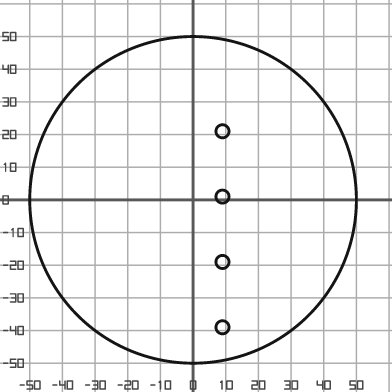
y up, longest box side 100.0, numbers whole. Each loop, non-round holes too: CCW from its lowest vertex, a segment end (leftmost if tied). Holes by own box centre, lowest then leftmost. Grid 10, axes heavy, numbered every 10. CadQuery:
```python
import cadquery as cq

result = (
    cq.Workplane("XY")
    .moveTo(0.0, 0.0)
    .circle(50.0)
    .moveTo(9.0, -39.0)
    .circle(2.0)
    .moveTo(9.0, -19.0)
    .circle(2.0)
    .moveTo(9.0, 1.0)
    .circle(2.0)
    .moveTo(9.0, 21.0)
    .circle(2.0)
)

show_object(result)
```